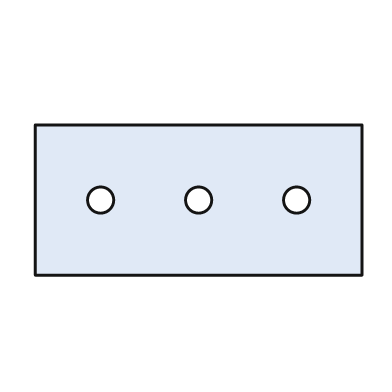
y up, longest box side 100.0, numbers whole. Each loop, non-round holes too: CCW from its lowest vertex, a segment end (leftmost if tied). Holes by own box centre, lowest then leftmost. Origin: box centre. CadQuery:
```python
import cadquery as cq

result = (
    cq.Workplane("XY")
    .moveTo(-50.0, -23.0)
    .lineTo(50.0, -23.0)
    .lineTo(50.0, 23.0)
    .lineTo(-50.0, 23.0)
    .close()
    .moveTo(-30.0, 0.0)
    .circle(4.0)
    .moveTo(0.0, 0.0)
    .circle(4.0)
    .moveTo(30.0, 0.0)
    .circle(4.0)
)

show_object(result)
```